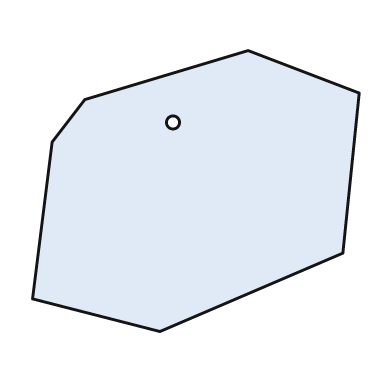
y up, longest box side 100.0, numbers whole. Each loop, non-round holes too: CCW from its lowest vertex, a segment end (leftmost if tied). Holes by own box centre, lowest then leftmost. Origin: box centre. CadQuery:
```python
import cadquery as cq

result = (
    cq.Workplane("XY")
    .moveTo(-11.0, -43.0)
    .lineTo(45.0, -19.0)
    .lineTo(50.0, 30.0)
    .lineTo(16.0, 43.0)
    .lineTo(-34.0, 28.0)
    .lineTo(-44.0, 15.0)
    .lineTo(-50.0, -33.0)
    .close()
    .moveTo(-7.0, 21.0)
    .circle(2.0)
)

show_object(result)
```